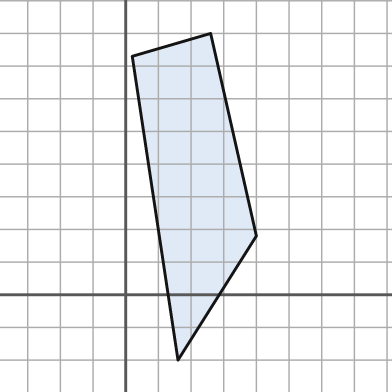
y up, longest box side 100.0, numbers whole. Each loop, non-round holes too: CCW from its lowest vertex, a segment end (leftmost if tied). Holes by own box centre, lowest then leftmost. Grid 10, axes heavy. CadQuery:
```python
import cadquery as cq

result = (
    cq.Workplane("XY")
    .moveTo(16.0, -20.0)
    .lineTo(40.0, 18.0)
    .lineTo(26.0, 80.0)
    .lineTo(2.0, 73.0)
    .close()
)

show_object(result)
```